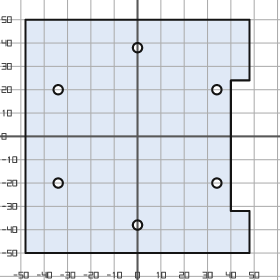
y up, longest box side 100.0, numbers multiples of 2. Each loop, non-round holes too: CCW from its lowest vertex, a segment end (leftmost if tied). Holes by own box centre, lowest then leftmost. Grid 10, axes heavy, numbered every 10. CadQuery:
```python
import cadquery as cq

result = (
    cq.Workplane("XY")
    .moveTo(-48.0, -50.0)
    .lineTo(48.0, -50.0)
    .lineTo(48.0, -32.0)
    .lineTo(40.0, -32.0)
    .lineTo(40.0, 24.0)
    .lineTo(48.0, 24.0)
    .lineTo(48.0, 50.0)
    .lineTo(-48.0, 50.0)
    .close()
    .moveTo(0.0, -38.0)
    .circle(2.0)
    .moveTo(-34.0, -20.0)
    .circle(2.0)
    .moveTo(34.0, -20.0)
    .circle(2.0)
    .moveTo(-34.0, 20.0)
    .circle(2.0)
    .moveTo(34.0, 20.0)
    .circle(2.0)
    .moveTo(0.0, 38.0)
    .circle(2.0)
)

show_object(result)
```